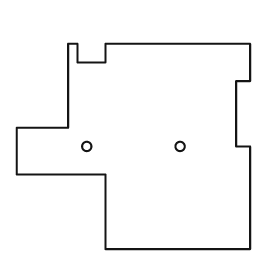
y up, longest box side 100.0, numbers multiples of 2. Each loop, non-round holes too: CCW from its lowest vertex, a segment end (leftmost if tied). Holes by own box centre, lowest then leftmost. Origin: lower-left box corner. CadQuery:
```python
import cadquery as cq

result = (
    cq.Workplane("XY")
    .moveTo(38.0, 0.0)
    .lineTo(100.0, 0.0)
    .lineTo(100.0, 44.0)
    .lineTo(94.0, 44.0)
    .lineTo(94.0, 72.0)
    .lineTo(100.0, 72.0)
    .lineTo(100.0, 88.0)
    .lineTo(38.0, 88.0)
    .lineTo(38.0, 80.0)
    .lineTo(26.0, 80.0)
    .lineTo(26.0, 88.0)
    .lineTo(22.0, 88.0)
    .lineTo(22.0, 52.0)
    .lineTo(0.0, 52.0)
    .lineTo(0.0, 32.0)
    .lineTo(38.0, 32.0)
    .close()
    .moveTo(30.0, 44.0)
    .circle(2.0)
    .moveTo(70.0, 44.0)
    .circle(2.0)
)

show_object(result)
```